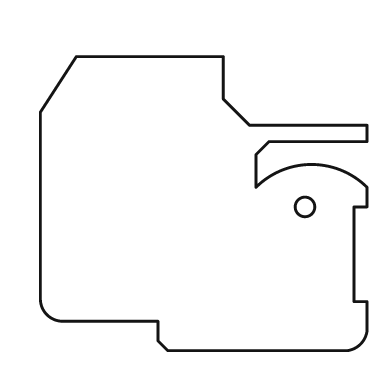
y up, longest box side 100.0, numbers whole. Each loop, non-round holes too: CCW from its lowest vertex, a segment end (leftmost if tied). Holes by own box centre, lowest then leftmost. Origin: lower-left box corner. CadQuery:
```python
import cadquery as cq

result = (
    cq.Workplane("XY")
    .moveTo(39.0, 0.0)
    .lineTo(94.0, 0.0)
    .threePointArc((98.0, 2.0), (100.0, 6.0))
    .lineTo(100.0, 15.0)
    .lineTo(96.0, 15.0)
    .lineTo(96.0, 44.0)
    .lineTo(100.0, 44.0)
    .lineTo(100.0, 50.0)
    .threePointArc((83.0, 57.0), (66.0, 50.0))
    .lineTo(66.0, 60.0)
    .lineTo(70.0, 64.0)
    .lineTo(100.0, 64.0)
    .lineTo(100.0, 69.0)
    .lineTo(64.0, 69.0)
    .lineTo(56.0, 77.0)
    .lineTo(56.0, 90.0)
    .lineTo(11.0, 90.0)
    .lineTo(0.0, 73.0)
    .lineTo(0.0, 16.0)
    .threePointArc((2.0, 11.0), (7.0, 9.0))
    .lineTo(36.0, 9.0)
    .lineTo(36.0, 3.0)
    .close()
    .moveTo(81.0, 44.0)
    .circle(3.0)
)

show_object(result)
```